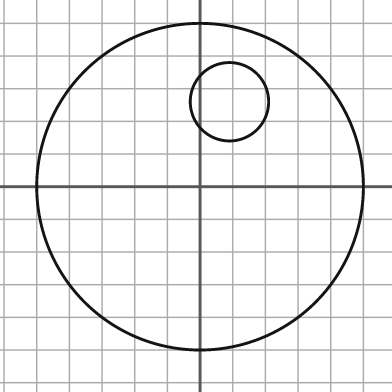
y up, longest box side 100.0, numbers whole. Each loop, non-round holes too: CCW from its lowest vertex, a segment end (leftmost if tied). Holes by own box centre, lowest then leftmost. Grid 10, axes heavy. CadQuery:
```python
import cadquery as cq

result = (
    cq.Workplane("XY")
    .moveTo(0.0, 0.0)
    .circle(50.0)
    .moveTo(9.0, 26.0)
    .circle(12.0)
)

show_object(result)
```